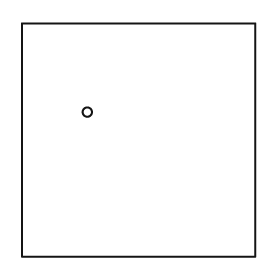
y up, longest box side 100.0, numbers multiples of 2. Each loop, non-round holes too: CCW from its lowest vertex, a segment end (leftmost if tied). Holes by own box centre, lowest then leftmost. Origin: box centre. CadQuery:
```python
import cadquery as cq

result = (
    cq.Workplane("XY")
    .moveTo(-50.0, -50.0)
    .lineTo(50.0, -50.0)
    .lineTo(50.0, 50.0)
    .lineTo(-50.0, 50.0)
    .close()
    .moveTo(-22.0, 12.0)
    .circle(2.0)
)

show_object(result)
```